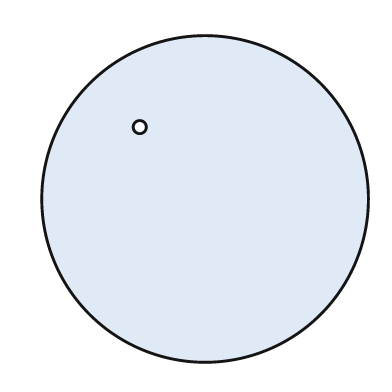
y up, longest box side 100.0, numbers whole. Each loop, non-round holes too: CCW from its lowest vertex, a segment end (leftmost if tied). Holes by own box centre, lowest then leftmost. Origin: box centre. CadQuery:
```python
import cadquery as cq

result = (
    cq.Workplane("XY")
    .moveTo(0.0, 0.0)
    .circle(50.0)
    .moveTo(-20.0, 22.0)
    .circle(2.0)
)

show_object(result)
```